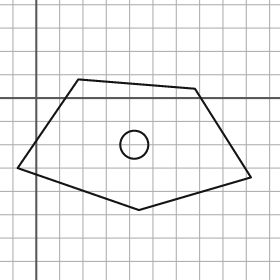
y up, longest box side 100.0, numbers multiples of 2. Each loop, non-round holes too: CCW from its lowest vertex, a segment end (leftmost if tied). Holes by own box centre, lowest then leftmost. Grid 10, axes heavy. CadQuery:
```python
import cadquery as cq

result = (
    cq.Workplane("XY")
    .moveTo(44.0, -48.0)
    .lineTo(92.0, -34.0)
    .lineTo(68.0, 4.0)
    .lineTo(18.0, 8.0)
    .lineTo(-8.0, -30.0)
    .close()
    .moveTo(42.0, -20.0)
    .circle(6.0)
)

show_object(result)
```